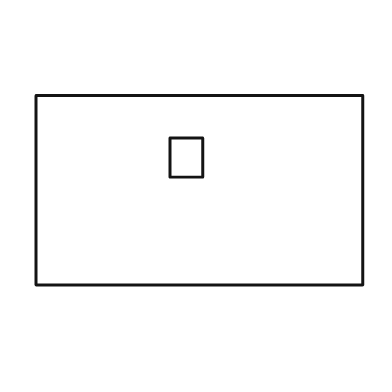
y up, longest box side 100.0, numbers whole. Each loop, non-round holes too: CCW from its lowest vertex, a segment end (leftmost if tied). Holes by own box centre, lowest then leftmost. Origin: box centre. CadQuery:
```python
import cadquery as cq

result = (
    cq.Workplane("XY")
    .moveTo(-50.0, -29.0)
    .lineTo(50.0, -29.0)
    .lineTo(50.0, 29.0)
    .lineTo(-50.0, 29.0)
    .close()
    .moveTo(-9.0, 4.0)
    .lineTo(1.0, 4.0)
    .lineTo(1.0, 16.0)
    .lineTo(-9.0, 16.0)
    .close()
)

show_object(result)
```